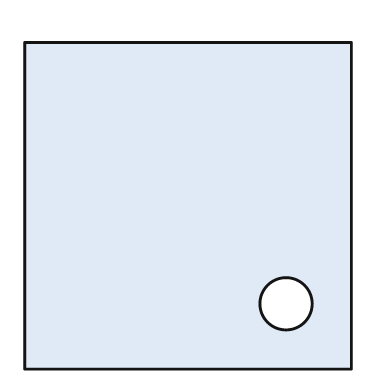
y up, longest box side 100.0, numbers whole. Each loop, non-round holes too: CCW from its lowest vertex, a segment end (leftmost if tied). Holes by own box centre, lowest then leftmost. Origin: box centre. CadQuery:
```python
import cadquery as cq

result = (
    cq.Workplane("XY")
    .moveTo(-50.0, -50.0)
    .lineTo(50.0, -50.0)
    .lineTo(50.0, 50.0)
    .lineTo(-50.0, 50.0)
    .close()
    .moveTo(30.0, -30.0)
    .circle(8.0)
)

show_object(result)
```